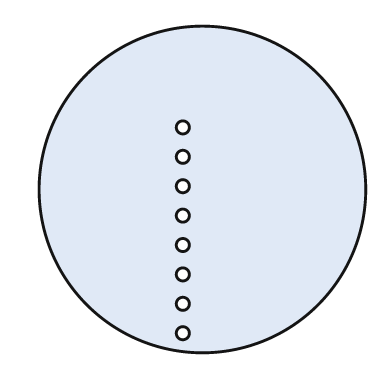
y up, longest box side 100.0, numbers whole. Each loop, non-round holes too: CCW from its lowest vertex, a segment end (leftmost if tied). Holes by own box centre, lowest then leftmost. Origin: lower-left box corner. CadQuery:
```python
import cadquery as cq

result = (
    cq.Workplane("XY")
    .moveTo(50.0, 50.0)
    .circle(50.0)
    .moveTo(44.0, 6.0)
    .circle(2.0)
    .moveTo(44.0, 15.0)
    .circle(2.0)
    .moveTo(44.0, 24.0)
    .circle(2.0)
    .moveTo(44.0, 33.0)
    .circle(2.0)
    .moveTo(44.0, 42.0)
    .circle(2.0)
    .moveTo(44.0, 51.0)
    .circle(2.0)
    .moveTo(44.0, 60.0)
    .circle(2.0)
    .moveTo(44.0, 69.0)
    .circle(2.0)
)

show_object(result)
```